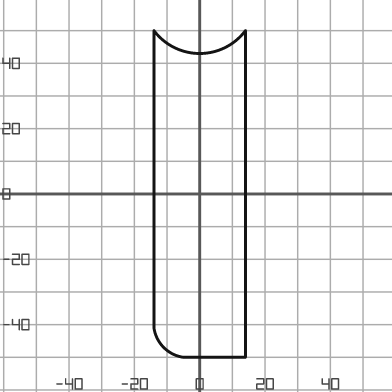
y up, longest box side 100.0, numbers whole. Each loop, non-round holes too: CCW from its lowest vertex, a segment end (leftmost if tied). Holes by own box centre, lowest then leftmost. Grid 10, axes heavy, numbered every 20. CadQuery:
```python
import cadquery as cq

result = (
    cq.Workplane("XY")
    .moveTo(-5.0, -50.0)
    .lineTo(14.0, -50.0)
    .lineTo(14.0, 50.0)
    .threePointArc((0.0, 43.0), (-14.0, 50.0))
    .lineTo(-14.0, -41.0)
    .threePointArc((-11.0, -47.0), (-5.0, -50.0))
    .close()
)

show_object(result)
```